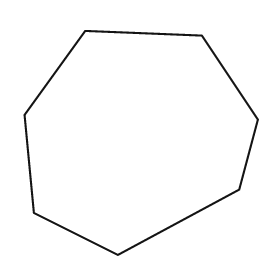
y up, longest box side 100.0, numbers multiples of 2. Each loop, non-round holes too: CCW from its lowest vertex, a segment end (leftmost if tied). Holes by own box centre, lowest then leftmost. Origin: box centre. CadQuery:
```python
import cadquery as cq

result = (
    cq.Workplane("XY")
    .moveTo(-10.0, -48.0)
    .lineTo(42.0, -20.0)
    .lineTo(50.0, 10.0)
    .lineTo(26.0, 46.0)
    .lineTo(-24.0, 48.0)
    .lineTo(-50.0, 12.0)
    .lineTo(-46.0, -30.0)
    .close()
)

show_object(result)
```